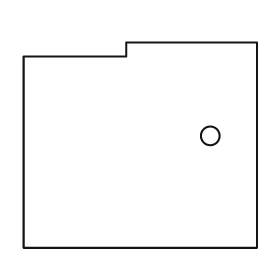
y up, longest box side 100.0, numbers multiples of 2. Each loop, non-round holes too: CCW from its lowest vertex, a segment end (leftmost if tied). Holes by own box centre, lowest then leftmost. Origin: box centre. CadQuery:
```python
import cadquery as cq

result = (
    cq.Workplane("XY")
    .moveTo(-50.0, -44.0)
    .lineTo(50.0, -44.0)
    .lineTo(50.0, 44.0)
    .lineTo(-6.0, 44.0)
    .lineTo(-6.0, 38.0)
    .lineTo(-50.0, 38.0)
    .close()
    .moveTo(30.0, 4.0)
    .circle(4.0)
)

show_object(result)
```